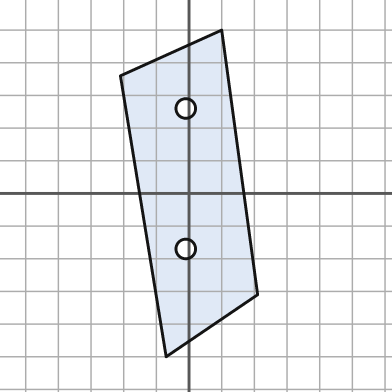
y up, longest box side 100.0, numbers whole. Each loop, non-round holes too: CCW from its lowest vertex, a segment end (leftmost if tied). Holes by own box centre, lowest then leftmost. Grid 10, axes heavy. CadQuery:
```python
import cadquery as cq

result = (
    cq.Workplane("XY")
    .moveTo(-7.0, -50.0)
    .lineTo(21.0, -31.0)
    .lineTo(10.0, 50.0)
    .lineTo(-21.0, 36.0)
    .close()
    .moveTo(-1.0, -17.0)
    .circle(3.0)
    .moveTo(-1.0, 26.0)
    .circle(3.0)
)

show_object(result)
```